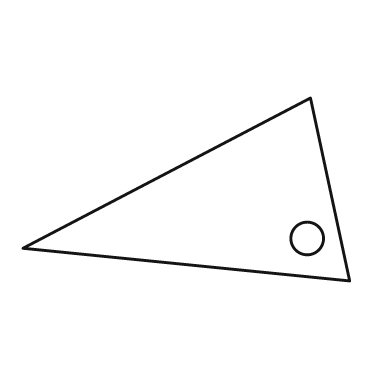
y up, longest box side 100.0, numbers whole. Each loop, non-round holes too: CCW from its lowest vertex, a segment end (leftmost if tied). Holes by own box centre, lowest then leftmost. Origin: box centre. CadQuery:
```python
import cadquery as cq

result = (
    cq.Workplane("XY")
    .moveTo(50.0, -28.0)
    .lineTo(38.0, 28.0)
    .lineTo(-50.0, -18.0)
    .close()
    .moveTo(37.0, -15.0)
    .circle(5.0)
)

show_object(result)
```